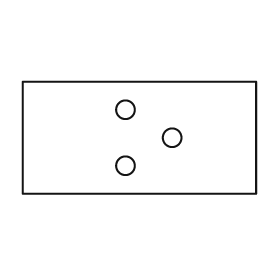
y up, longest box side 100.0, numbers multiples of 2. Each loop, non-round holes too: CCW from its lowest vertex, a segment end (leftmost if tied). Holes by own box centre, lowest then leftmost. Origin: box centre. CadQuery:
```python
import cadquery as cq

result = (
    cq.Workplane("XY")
    .moveTo(-50.0, -24.0)
    .lineTo(50.0, -24.0)
    .lineTo(50.0, 24.0)
    .lineTo(-50.0, 24.0)
    .close()
    .moveTo(-6.0, -12.0)
    .circle(4.0)
    .moveTo(14.0, 0.0)
    .circle(4.0)
    .moveTo(-6.0, 12.0)
    .circle(4.0)
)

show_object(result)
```